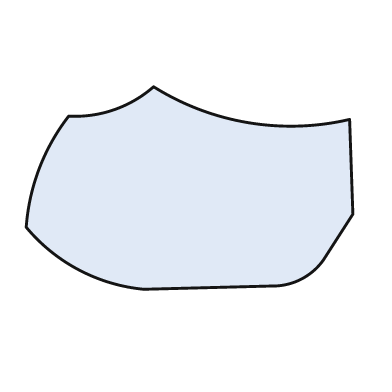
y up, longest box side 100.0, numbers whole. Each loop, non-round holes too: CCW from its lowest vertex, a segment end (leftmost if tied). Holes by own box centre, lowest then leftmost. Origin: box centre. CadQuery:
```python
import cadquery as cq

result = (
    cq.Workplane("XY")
    .moveTo(-14.0, -31.0)
    .lineTo(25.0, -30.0)
    .threePointArc((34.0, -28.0), (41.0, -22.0))
    .lineTo(50.0, -8.0)
    .lineTo(49.0, 21.0)
    .threePointArc((18.0, 20.0), (-11.0, 31.0))
    .threePointArc((-23.0, 24.0), (-37.0, 22.0))
    .threePointArc((-46.0, 6.0), (-50.0, -12.0))
    .threePointArc((-34.0, -25.0), (-14.0, -31.0))
    .close()
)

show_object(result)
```